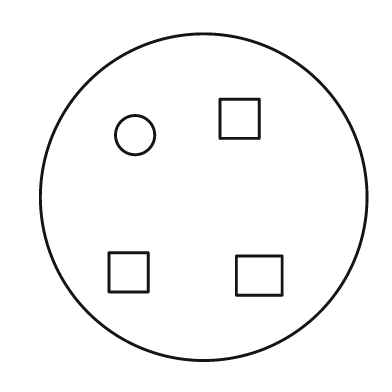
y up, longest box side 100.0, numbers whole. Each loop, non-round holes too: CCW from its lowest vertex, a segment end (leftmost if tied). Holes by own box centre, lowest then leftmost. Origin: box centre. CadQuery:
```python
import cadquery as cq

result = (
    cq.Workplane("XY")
    .moveTo(0.0, 0.0)
    .circle(50.0)
    .moveTo(10.0, -30.0)
    .lineTo(24.0, -30.0)
    .lineTo(24.0, -18.0)
    .lineTo(10.0, -18.0)
    .close()
    .moveTo(-29.0, -29.0)
    .lineTo(-17.0, -29.0)
    .lineTo(-17.0, -17.0)
    .lineTo(-29.0, -17.0)
    .close()
    .moveTo(-21.0, 19.0)
    .circle(6.0)
    .moveTo(5.0, 18.0)
    .lineTo(17.0, 18.0)
    .lineTo(17.0, 30.0)
    .lineTo(5.0, 30.0)
    .close()
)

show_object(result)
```